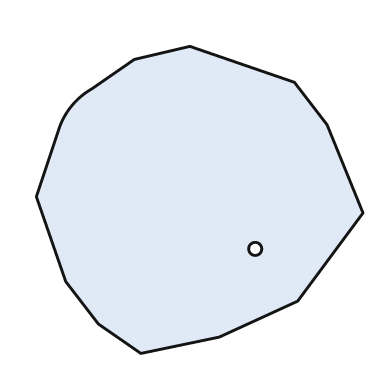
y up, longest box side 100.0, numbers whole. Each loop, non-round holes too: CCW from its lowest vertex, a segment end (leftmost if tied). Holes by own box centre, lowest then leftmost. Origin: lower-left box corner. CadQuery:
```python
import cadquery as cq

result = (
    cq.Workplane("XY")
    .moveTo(32.0, 0.0)
    .lineTo(56.0, 5.0)
    .lineTo(80.0, 16.0)
    .lineTo(100.0, 43.0)
    .lineTo(89.0, 70.0)
    .lineTo(79.0, 83.0)
    .lineTo(47.0, 94.0)
    .lineTo(30.0, 90.0)
    .lineTo(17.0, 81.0)
    .threePointArc((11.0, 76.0), (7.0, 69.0))
    .lineTo(0.0, 48.0)
    .lineTo(9.0, 22.0)
    .lineTo(19.0, 9.0)
    .close()
    .moveTo(67.0, 32.0)
    .circle(2.0)
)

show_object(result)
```